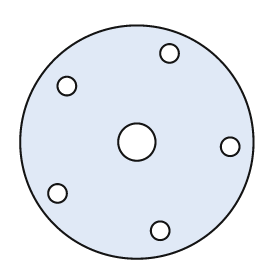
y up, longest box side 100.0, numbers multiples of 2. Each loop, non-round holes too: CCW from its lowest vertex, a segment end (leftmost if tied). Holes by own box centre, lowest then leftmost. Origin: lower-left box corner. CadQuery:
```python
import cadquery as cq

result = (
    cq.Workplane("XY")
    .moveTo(50.0, 50.0)
    .circle(50.0)
    .moveTo(60.0, 12.0)
    .circle(4.0)
    .moveTo(16.0, 28.0)
    .circle(4.0)
    .moveTo(90.0, 48.0)
    .circle(4.0)
    .moveTo(50.0, 50.0)
    .circle(8.0)
    .moveTo(20.0, 74.0)
    .circle(4.0)
    .moveTo(64.0, 88.0)
    .circle(4.0)
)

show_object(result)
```